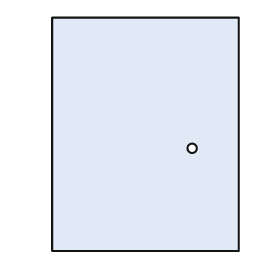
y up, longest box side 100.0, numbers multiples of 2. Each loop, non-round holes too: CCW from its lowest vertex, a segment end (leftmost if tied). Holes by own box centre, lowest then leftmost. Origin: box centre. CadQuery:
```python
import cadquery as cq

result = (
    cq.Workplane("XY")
    .moveTo(-40.0, -50.0)
    .lineTo(40.0, -50.0)
    .lineTo(40.0, 50.0)
    .lineTo(-40.0, 50.0)
    .close()
    .moveTo(20.0, -6.0)
    .circle(2.0)
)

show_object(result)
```